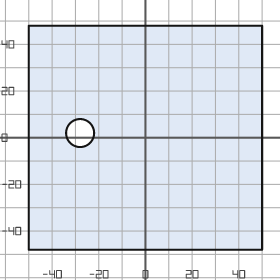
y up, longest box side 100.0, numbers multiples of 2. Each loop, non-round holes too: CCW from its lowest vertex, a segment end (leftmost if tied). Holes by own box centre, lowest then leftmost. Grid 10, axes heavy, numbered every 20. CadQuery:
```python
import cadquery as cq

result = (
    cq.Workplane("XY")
    .moveTo(-50.0, -48.0)
    .lineTo(50.0, -48.0)
    .lineTo(50.0, 48.0)
    .lineTo(-50.0, 48.0)
    .close()
    .moveTo(-28.0, 2.0)
    .circle(6.0)
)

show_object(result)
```